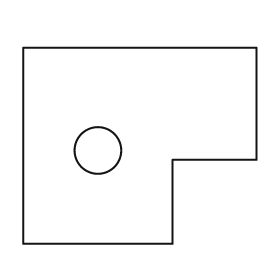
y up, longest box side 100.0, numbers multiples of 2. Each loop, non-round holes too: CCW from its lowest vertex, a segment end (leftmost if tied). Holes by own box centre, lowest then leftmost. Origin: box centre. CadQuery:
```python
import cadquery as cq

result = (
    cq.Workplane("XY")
    .moveTo(-50.0, -42.0)
    .lineTo(14.0, -42.0)
    .lineTo(14.0, -6.0)
    .lineTo(50.0, -6.0)
    .lineTo(50.0, 42.0)
    .lineTo(-50.0, 42.0)
    .close()
    .moveTo(-18.0, -2.0)
    .circle(10.0)
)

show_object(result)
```